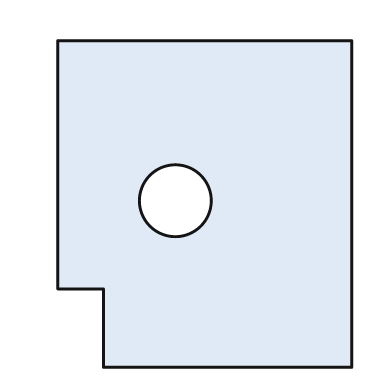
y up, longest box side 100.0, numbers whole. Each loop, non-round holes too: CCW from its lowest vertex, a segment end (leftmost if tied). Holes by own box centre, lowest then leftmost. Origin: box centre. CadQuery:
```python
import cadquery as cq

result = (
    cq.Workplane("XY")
    .moveTo(-31.0, -50.0)
    .lineTo(45.0, -50.0)
    .lineTo(45.0, 50.0)
    .lineTo(-45.0, 50.0)
    .lineTo(-45.0, -26.0)
    .lineTo(-31.0, -26.0)
    .close()
    .moveTo(-9.0, 1.0)
    .circle(11.0)
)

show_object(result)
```